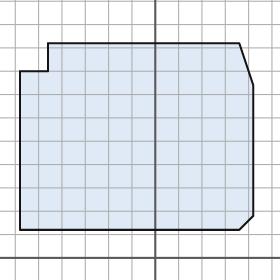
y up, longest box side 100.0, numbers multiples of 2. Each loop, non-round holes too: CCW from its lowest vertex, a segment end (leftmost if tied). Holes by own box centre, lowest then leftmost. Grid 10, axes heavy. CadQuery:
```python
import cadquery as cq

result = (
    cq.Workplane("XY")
    .moveTo(-58.0, 12.0)
    .lineTo(36.0, 12.0)
    .lineTo(42.0, 18.0)
    .lineTo(42.0, 74.0)
    .lineTo(36.0, 92.0)
    .lineTo(-46.0, 92.0)
    .lineTo(-46.0, 80.0)
    .lineTo(-58.0, 80.0)
    .close()
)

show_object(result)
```